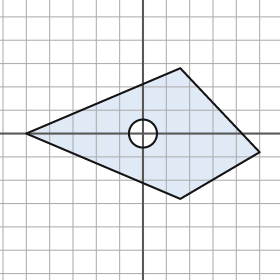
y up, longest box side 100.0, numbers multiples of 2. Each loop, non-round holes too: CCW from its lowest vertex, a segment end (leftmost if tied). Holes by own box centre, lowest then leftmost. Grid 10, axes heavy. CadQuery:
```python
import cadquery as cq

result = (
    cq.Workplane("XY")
    .moveTo(16.0, -28.0)
    .lineTo(50.0, -8.0)
    .lineTo(16.0, 28.0)
    .lineTo(-50.0, 0.0)
    .close()
    .moveTo(0.0, 0.0)
    .circle(6.0)
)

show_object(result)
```